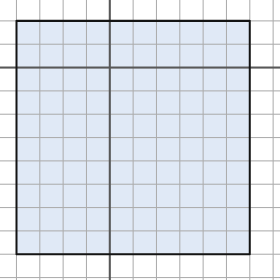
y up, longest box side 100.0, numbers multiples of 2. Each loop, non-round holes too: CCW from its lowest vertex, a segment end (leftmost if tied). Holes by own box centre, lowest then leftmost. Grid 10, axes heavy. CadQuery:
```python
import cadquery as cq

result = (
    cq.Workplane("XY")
    .moveTo(-40.0, -80.0)
    .lineTo(60.0, -80.0)
    .lineTo(60.0, 20.0)
    .lineTo(-40.0, 20.0)
    .close()
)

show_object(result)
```